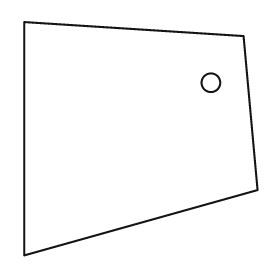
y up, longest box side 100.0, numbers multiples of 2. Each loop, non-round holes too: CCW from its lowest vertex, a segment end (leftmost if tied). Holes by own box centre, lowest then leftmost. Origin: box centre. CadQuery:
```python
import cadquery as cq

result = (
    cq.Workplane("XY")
    .moveTo(-50.0, -50.0)
    .lineTo(50.0, -22.0)
    .lineTo(44.0, 44.0)
    .lineTo(-50.0, 50.0)
    .close()
    .moveTo(30.0, 24.0)
    .circle(4.0)
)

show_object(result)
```